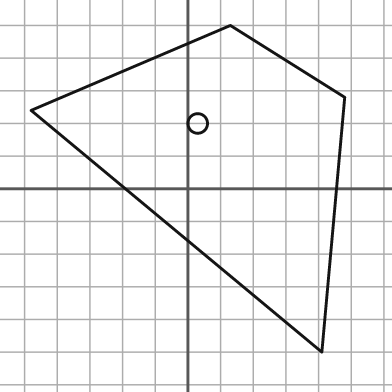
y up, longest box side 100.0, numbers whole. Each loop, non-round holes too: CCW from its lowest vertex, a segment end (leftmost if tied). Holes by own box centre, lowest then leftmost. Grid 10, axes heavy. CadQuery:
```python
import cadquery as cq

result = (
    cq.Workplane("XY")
    .moveTo(41.0, -50.0)
    .lineTo(48.0, 28.0)
    .lineTo(13.0, 50.0)
    .lineTo(-48.0, 24.0)
    .close()
    .moveTo(3.0, 20.0)
    .circle(3.0)
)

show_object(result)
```